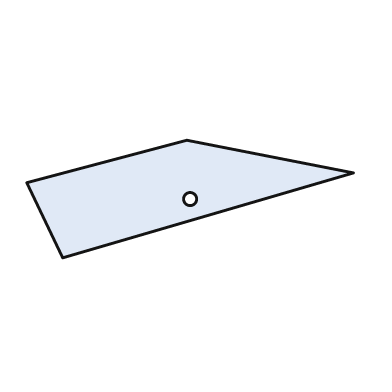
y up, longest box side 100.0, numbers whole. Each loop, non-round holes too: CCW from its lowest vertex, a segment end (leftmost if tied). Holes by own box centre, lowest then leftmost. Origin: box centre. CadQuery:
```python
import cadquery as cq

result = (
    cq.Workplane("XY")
    .moveTo(-39.0, -18.0)
    .lineTo(50.0, 8.0)
    .lineTo(-1.0, 18.0)
    .lineTo(-50.0, 5.0)
    .close()
    .moveTo(0.0, 0.0)
    .circle(2.0)
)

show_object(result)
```